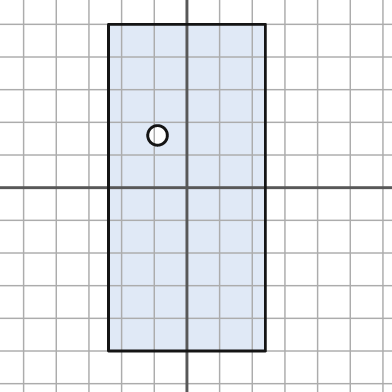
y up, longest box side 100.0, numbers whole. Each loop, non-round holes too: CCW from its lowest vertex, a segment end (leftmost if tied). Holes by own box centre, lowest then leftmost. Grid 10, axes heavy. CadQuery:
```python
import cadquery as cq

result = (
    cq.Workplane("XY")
    .moveTo(-24.0, -50.0)
    .lineTo(24.0, -50.0)
    .lineTo(24.0, 50.0)
    .lineTo(-24.0, 50.0)
    .close()
    .moveTo(-9.0, 16.0)
    .circle(3.0)
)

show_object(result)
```